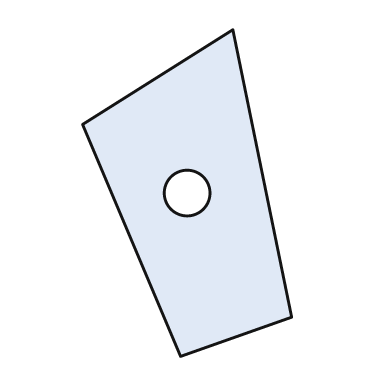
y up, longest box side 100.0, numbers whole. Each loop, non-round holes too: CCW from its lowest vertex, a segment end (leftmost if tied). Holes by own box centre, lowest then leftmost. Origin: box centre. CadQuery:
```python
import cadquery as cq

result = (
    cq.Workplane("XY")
    .moveTo(-2.0, -50.0)
    .lineTo(32.0, -38.0)
    .lineTo(14.0, 50.0)
    .lineTo(-32.0, 21.0)
    .close()
    .moveTo(0.0, 0.0)
    .circle(7.0)
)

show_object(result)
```